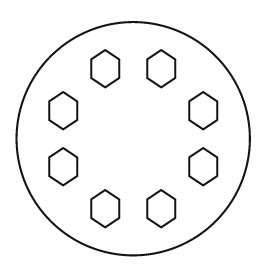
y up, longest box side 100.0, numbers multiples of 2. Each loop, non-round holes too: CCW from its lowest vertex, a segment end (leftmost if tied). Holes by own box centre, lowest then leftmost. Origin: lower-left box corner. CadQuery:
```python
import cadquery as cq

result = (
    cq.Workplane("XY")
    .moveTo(50.0, 50.0)
    .circle(50.0)
    .moveTo(38.0, 12.0)
    .lineTo(44.0, 16.0)
    .lineTo(44.0, 24.0)
    .lineTo(38.0, 28.0)
    .lineTo(32.0, 24.0)
    .lineTo(32.0, 16.0)
    .close()
    .moveTo(62.0, 12.0)
    .lineTo(68.0, 16.0)
    .lineTo(68.0, 24.0)
    .lineTo(62.0, 28.0)
    .lineTo(56.0, 24.0)
    .lineTo(56.0, 16.0)
    .close()
    .moveTo(20.0, 30.0)
    .lineTo(26.0, 34.0)
    .lineTo(26.0, 42.0)
    .lineTo(20.0, 46.0)
    .lineTo(14.0, 42.0)
    .lineTo(14.0, 34.0)
    .close()
    .moveTo(80.0, 30.0)
    .lineTo(86.0, 34.0)
    .lineTo(86.0, 42.0)
    .lineTo(80.0, 46.0)
    .lineTo(74.0, 42.0)
    .lineTo(74.0, 34.0)
    .close()
    .moveTo(20.0, 54.0)
    .lineTo(26.0, 58.0)
    .lineTo(26.0, 66.0)
    .lineTo(20.0, 70.0)
    .lineTo(14.0, 66.0)
    .lineTo(14.0, 58.0)
    .close()
    .moveTo(80.0, 54.0)
    .lineTo(86.0, 58.0)
    .lineTo(86.0, 66.0)
    .lineTo(80.0, 70.0)
    .lineTo(74.0, 66.0)
    .lineTo(74.0, 58.0)
    .close()
    .moveTo(38.0, 72.0)
    .lineTo(44.0, 76.0)
    .lineTo(44.0, 84.0)
    .lineTo(38.0, 88.0)
    .lineTo(32.0, 84.0)
    .lineTo(32.0, 76.0)
    .close()
    .moveTo(62.0, 72.0)
    .lineTo(68.0, 76.0)
    .lineTo(68.0, 84.0)
    .lineTo(62.0, 88.0)
    .lineTo(56.0, 84.0)
    .lineTo(56.0, 76.0)
    .close()
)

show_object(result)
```